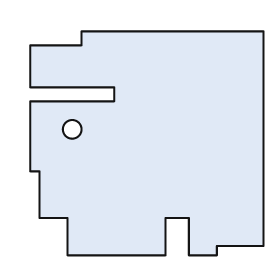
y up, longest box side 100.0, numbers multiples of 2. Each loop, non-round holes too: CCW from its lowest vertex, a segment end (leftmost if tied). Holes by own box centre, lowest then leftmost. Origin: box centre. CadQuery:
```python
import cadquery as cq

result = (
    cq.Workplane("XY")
    .moveTo(-34.0, -48.0)
    .lineTo(8.0, -48.0)
    .lineTo(8.0, -32.0)
    .lineTo(18.0, -32.0)
    .lineTo(18.0, -48.0)
    .lineTo(30.0, -48.0)
    .lineTo(30.0, -44.0)
    .lineTo(50.0, -44.0)
    .lineTo(50.0, 48.0)
    .lineTo(-28.0, 48.0)
    .lineTo(-28.0, 42.0)
    .lineTo(-50.0, 42.0)
    .lineTo(-50.0, 24.0)
    .lineTo(-14.0, 24.0)
    .lineTo(-14.0, 18.0)
    .lineTo(-50.0, 18.0)
    .lineTo(-50.0, -12.0)
    .lineTo(-46.0, -12.0)
    .lineTo(-46.0, -32.0)
    .lineTo(-34.0, -32.0)
    .close()
    .moveTo(-32.0, 6.0)
    .circle(4.0)
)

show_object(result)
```